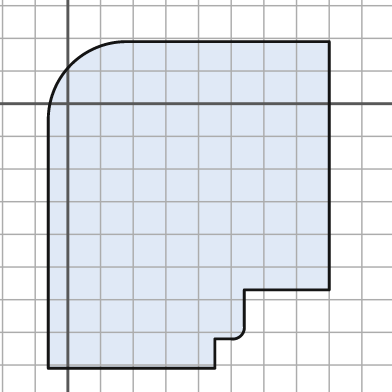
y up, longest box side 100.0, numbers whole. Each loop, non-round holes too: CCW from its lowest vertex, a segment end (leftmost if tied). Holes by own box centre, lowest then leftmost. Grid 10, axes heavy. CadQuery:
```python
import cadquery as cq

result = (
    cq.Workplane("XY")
    .moveTo(-6.0, -81.0)
    .lineTo(45.0, -81.0)
    .lineTo(45.0, -72.0)
    .lineTo(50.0, -72.0)
    .threePointArc((53.0, -71.0), (54.0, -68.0))
    .lineTo(54.0, -57.0)
    .lineTo(80.0, -57.0)
    .lineTo(80.0, 19.0)
    .lineTo(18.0, 19.0)
    .threePointArc((1.0, 12.0), (-6.0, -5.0))
    .close()
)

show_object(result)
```